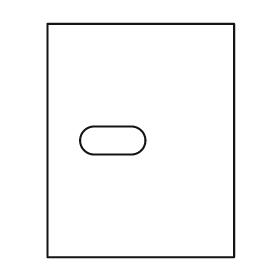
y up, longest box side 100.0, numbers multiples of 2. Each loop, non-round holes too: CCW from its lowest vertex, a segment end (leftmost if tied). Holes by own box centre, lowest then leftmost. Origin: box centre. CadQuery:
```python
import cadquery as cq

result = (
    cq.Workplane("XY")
    .moveTo(-40.0, -50.0)
    .lineTo(40.0, -50.0)
    .lineTo(40.0, 50.0)
    .lineTo(-40.0, 50.0)
    .close()
    .moveTo(-20.0, -6.0)
    .lineTo(-4.0, -6.0)
    .threePointArc((2.0, 0.0), (-4.0, 6.0))
    .lineTo(-20.0, 6.0)
    .threePointArc((-26.0, 0.0), (-20.0, -6.0))
    .close()
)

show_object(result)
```